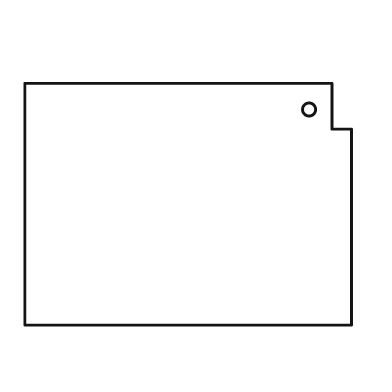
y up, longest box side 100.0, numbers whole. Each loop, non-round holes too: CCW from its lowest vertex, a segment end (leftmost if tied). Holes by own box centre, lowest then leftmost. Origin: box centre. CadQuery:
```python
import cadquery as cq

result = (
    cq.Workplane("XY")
    .moveTo(-50.0, -37.0)
    .lineTo(50.0, -37.0)
    .lineTo(50.0, 23.0)
    .lineTo(44.0, 23.0)
    .lineTo(44.0, 37.0)
    .lineTo(-50.0, 37.0)
    .close()
    .moveTo(37.0, 29.0)
    .circle(2.0)
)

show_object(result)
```